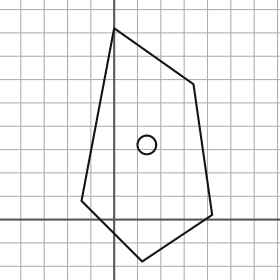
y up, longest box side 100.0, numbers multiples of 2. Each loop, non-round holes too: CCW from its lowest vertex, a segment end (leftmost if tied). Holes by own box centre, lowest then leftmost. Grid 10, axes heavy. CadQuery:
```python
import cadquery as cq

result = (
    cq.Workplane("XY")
    .moveTo(12.0, -18.0)
    .lineTo(42.0, 2.0)
    .lineTo(34.0, 58.0)
    .lineTo(0.0, 82.0)
    .lineTo(-14.0, 8.0)
    .close()
    .moveTo(14.0, 32.0)
    .circle(4.0)
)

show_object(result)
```